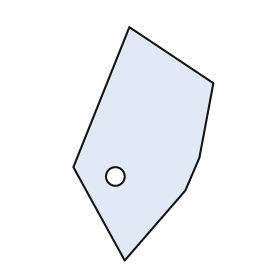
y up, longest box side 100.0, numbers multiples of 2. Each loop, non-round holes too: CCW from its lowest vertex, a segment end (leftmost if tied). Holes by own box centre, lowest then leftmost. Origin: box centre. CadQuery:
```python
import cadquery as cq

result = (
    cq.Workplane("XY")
    .moveTo(-8.0, -50.0)
    .lineTo(18.0, -20.0)
    .lineTo(24.0, -6.0)
    .lineTo(30.0, 26.0)
    .lineTo(-6.0, 50.0)
    .lineTo(-30.0, -10.0)
    .close()
    .moveTo(-12.0, -14.0)
    .circle(4.0)
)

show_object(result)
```